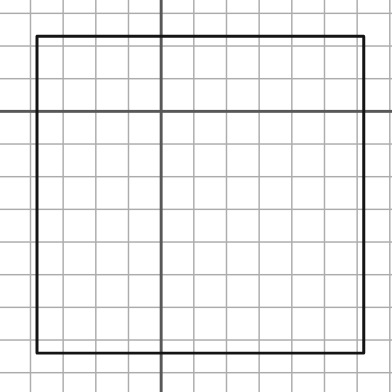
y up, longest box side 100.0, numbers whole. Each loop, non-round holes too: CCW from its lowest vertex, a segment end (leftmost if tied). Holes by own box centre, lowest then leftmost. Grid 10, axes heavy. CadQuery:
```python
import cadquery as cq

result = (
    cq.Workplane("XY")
    .moveTo(-38.0, -74.0)
    .lineTo(62.0, -74.0)
    .lineTo(62.0, 23.0)
    .lineTo(-38.0, 23.0)
    .close()
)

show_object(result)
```